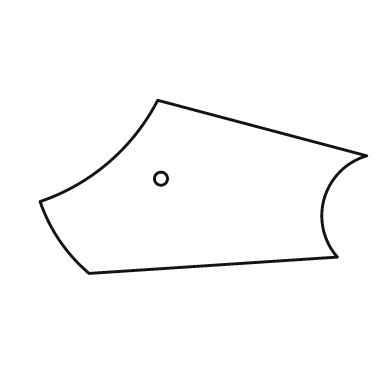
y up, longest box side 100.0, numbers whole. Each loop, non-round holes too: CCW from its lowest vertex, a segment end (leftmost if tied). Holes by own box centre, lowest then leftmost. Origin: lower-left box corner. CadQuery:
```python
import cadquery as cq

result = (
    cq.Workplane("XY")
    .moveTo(15.0, 0.0)
    .lineTo(91.0, 5.0)
    .threePointArc((87.0, 23.0), (100.0, 36.0))
    .lineTo(36.0, 53.0)
    .threePointArc((21.0, 34.0), (0.0, 22.0))
    .threePointArc((6.0, 10.0), (15.0, 0.0))
    .close()
    .moveTo(37.0, 29.0)
    .circle(2.0)
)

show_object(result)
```